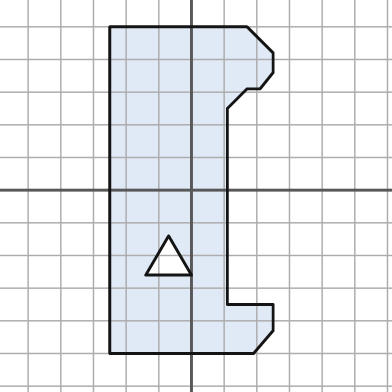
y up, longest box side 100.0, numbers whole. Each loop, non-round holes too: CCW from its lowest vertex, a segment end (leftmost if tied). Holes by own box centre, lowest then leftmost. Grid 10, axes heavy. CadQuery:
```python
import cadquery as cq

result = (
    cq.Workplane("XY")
    .moveTo(-25.0, -50.0)
    .lineTo(19.0, -50.0)
    .lineTo(25.0, -43.0)
    .lineTo(25.0, -35.0)
    .lineTo(11.0, -35.0)
    .lineTo(11.0, 25.0)
    .lineTo(17.0, 31.0)
    .lineTo(21.0, 31.0)
    .lineTo(25.0, 36.0)
    .lineTo(25.0, 42.0)
    .lineTo(17.0, 50.0)
    .lineTo(-25.0, 50.0)
    .close()
    .moveTo(-14.0, -26.0)
    .lineTo(0.0, -26.0)
    .lineTo(-7.0, -14.0)
    .close()
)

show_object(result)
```